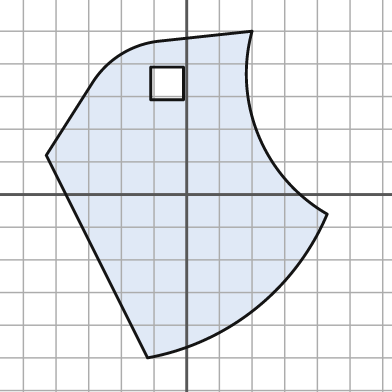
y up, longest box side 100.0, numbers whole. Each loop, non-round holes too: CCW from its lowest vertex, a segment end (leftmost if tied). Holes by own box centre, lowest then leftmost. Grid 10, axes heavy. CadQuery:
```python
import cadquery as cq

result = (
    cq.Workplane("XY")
    .moveTo(-12.0, -50.0)
    .threePointArc((21.0, -35.0), (43.0, -6.0))
    .threePointArc((22.0, 18.0), (20.0, 50.0))
    .lineTo(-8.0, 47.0)
    .threePointArc((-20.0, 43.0), (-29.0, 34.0))
    .lineTo(-43.0, 12.0)
    .close()
    .moveTo(-11.0, 29.0)
    .lineTo(-1.0, 29.0)
    .lineTo(-1.0, 39.0)
    .lineTo(-11.0, 39.0)
    .close()
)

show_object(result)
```